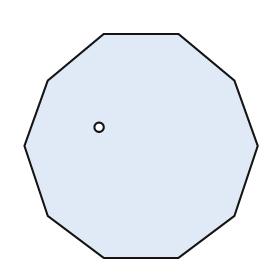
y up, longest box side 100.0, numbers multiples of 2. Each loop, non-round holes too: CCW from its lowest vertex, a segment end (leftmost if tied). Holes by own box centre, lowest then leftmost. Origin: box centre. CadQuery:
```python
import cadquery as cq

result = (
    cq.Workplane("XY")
    .moveTo(-16.0, -48.0)
    .lineTo(16.0, -48.0)
    .lineTo(40.0, -30.0)
    .lineTo(50.0, 0.0)
    .lineTo(40.0, 28.0)
    .lineTo(16.0, 48.0)
    .lineTo(-16.0, 48.0)
    .lineTo(-40.0, 28.0)
    .lineTo(-50.0, 0.0)
    .lineTo(-40.0, -30.0)
    .close()
    .moveTo(-18.0, 8.0)
    .circle(2.0)
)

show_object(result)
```